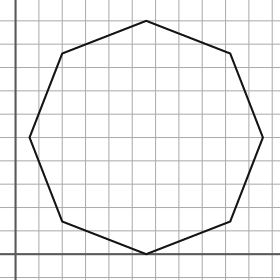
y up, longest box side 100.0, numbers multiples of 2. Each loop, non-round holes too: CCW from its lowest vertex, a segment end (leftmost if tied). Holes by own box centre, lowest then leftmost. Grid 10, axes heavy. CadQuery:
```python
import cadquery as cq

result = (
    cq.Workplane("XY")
    .moveTo(56.0, 0.0)
    .lineTo(92.0, 14.0)
    .lineTo(106.0, 50.0)
    .lineTo(92.0, 86.0)
    .lineTo(56.0, 100.0)
    .lineTo(20.0, 86.0)
    .lineTo(6.0, 50.0)
    .lineTo(20.0, 14.0)
    .close()
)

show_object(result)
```